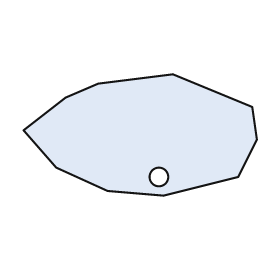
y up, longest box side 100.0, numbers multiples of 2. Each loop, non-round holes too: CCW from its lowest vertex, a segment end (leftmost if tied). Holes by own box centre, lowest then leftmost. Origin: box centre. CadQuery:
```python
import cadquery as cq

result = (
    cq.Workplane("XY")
    .moveTo(10.0, -26.0)
    .lineTo(42.0, -18.0)
    .lineTo(50.0, -2.0)
    .lineTo(48.0, 12.0)
    .lineTo(14.0, 26.0)
    .lineTo(-18.0, 22.0)
    .lineTo(-32.0, 16.0)
    .lineTo(-50.0, 2.0)
    .lineTo(-36.0, -14.0)
    .lineTo(-14.0, -24.0)
    .close()
    .moveTo(8.0, -18.0)
    .circle(4.0)
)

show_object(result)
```